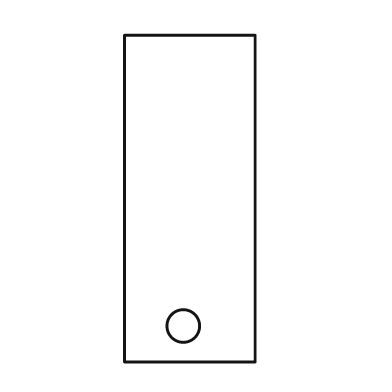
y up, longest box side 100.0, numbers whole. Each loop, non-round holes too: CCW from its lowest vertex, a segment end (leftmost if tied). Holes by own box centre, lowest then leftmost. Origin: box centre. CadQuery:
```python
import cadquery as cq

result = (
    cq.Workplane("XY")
    .moveTo(-20.0, -50.0)
    .lineTo(20.0, -50.0)
    .lineTo(20.0, 50.0)
    .lineTo(-20.0, 50.0)
    .close()
    .moveTo(-2.0, -39.0)
    .circle(5.0)
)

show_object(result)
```